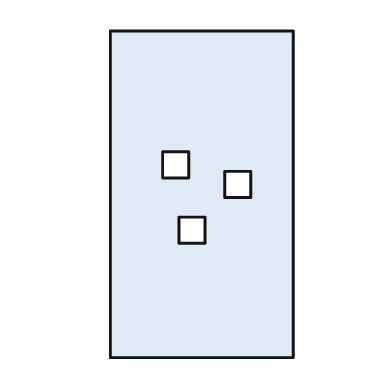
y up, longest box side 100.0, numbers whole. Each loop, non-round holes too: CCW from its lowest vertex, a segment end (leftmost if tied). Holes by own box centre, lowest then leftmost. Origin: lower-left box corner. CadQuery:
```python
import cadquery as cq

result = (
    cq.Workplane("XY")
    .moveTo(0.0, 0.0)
    .lineTo(56.0, 0.0)
    .lineTo(56.0, 100.0)
    .lineTo(0.0, 100.0)
    .close()
    .moveTo(21.0, 35.0)
    .lineTo(29.0, 35.0)
    .lineTo(29.0, 43.0)
    .lineTo(21.0, 43.0)
    .close()
    .moveTo(35.0, 49.0)
    .lineTo(43.0, 49.0)
    .lineTo(43.0, 57.0)
    .lineTo(35.0, 57.0)
    .close()
    .moveTo(16.0, 55.0)
    .lineTo(24.0, 55.0)
    .lineTo(24.0, 63.0)
    .lineTo(16.0, 63.0)
    .close()
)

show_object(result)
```